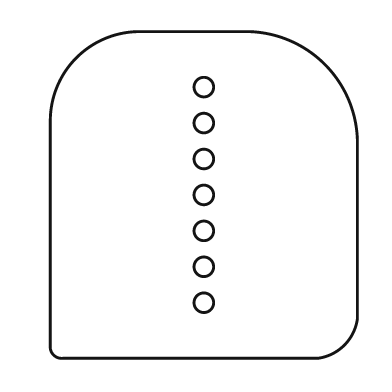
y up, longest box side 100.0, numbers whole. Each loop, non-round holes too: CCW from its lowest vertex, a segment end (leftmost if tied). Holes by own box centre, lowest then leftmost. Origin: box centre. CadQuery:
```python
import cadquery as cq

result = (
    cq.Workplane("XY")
    .moveTo(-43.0, -50.0)
    .lineTo(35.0, -50.0)
    .threePointArc((43.0, -46.0), (47.0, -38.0))
    .lineTo(47.0, 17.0)
    .threePointArc((37.0, 40.0), (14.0, 50.0))
    .lineTo(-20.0, 50.0)
    .threePointArc((-39.0, 42.0), (-47.0, 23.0))
    .lineTo(-47.0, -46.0)
    .threePointArc((-46.0, -49.0), (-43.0, -50.0))
    .close()
    .moveTo(0.0, -33.0)
    .circle(3.0)
    .moveTo(0.0, -22.0)
    .circle(3.0)
    .moveTo(0.0, -11.0)
    .circle(3.0)
    .moveTo(0.0, 0.0)
    .circle(3.0)
    .moveTo(0.0, 11.0)
    .circle(3.0)
    .moveTo(0.0, 22.0)
    .circle(3.0)
    .moveTo(0.0, 33.0)
    .circle(3.0)
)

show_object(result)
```